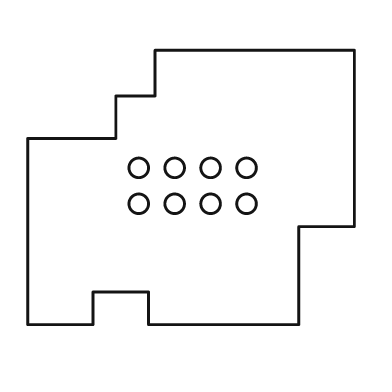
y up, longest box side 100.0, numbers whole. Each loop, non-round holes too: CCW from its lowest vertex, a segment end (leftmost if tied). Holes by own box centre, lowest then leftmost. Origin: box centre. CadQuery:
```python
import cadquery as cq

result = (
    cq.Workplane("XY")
    .moveTo(-50.0, -42.0)
    .lineTo(-30.0, -42.0)
    .lineTo(-30.0, -32.0)
    .lineTo(-13.0, -32.0)
    .lineTo(-13.0, -42.0)
    .lineTo(33.0, -42.0)
    .lineTo(33.0, -12.0)
    .lineTo(50.0, -12.0)
    .lineTo(50.0, 42.0)
    .lineTo(-11.0, 42.0)
    .lineTo(-11.0, 28.0)
    .lineTo(-23.0, 28.0)
    .lineTo(-23.0, 15.0)
    .lineTo(-50.0, 15.0)
    .close()
    .moveTo(-16.0, -5.0)
    .circle(3.0)
    .moveTo(-5.0, -5.0)
    .circle(3.0)
    .moveTo(6.0, -5.0)
    .circle(3.0)
    .moveTo(17.0, -5.0)
    .circle(3.0)
    .moveTo(-16.0, 6.0)
    .circle(3.0)
    .moveTo(-5.0, 6.0)
    .circle(3.0)
    .moveTo(6.0, 6.0)
    .circle(3.0)
    .moveTo(17.0, 6.0)
    .circle(3.0)
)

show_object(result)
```